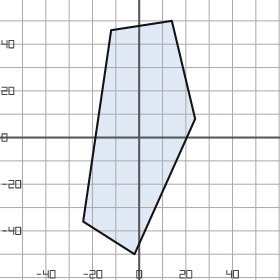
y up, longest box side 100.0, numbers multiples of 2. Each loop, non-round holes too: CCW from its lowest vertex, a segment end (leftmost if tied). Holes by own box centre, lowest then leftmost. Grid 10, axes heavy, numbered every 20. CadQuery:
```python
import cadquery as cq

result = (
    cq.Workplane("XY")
    .moveTo(-2.0, -50.0)
    .lineTo(24.0, 8.0)
    .lineTo(14.0, 50.0)
    .lineTo(-12.0, 46.0)
    .lineTo(-24.0, -36.0)
    .close()
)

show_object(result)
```